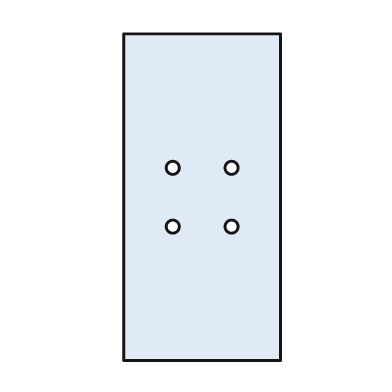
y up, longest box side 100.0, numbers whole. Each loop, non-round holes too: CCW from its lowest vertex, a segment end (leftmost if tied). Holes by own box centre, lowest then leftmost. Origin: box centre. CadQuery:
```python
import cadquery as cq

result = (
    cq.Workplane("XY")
    .moveTo(-24.0, -50.0)
    .lineTo(24.0, -50.0)
    .lineTo(24.0, 50.0)
    .lineTo(-24.0, 50.0)
    .close()
    .moveTo(-9.0, -9.0)
    .circle(2.0)
    .moveTo(9.0, -9.0)
    .circle(2.0)
    .moveTo(-9.0, 9.0)
    .circle(2.0)
    .moveTo(9.0, 9.0)
    .circle(2.0)
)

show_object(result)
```